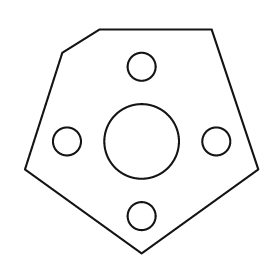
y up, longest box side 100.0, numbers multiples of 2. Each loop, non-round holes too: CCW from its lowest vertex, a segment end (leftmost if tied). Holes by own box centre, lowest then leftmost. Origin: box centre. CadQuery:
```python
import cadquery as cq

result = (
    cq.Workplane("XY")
    .moveTo(0.0, -48.0)
    .lineTo(50.0, -12.0)
    .lineTo(30.0, 48.0)
    .lineTo(-18.0, 48.0)
    .lineTo(-34.0, 38.0)
    .lineTo(-50.0, -12.0)
    .close()
    .moveTo(0.0, -32.0)
    .circle(6.0)
    .moveTo(-32.0, 0.0)
    .circle(6.0)
    .moveTo(0.0, 0.0)
    .circle(16.0)
    .moveTo(32.0, 0.0)
    .circle(6.0)
    .moveTo(0.0, 32.0)
    .circle(6.0)
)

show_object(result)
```